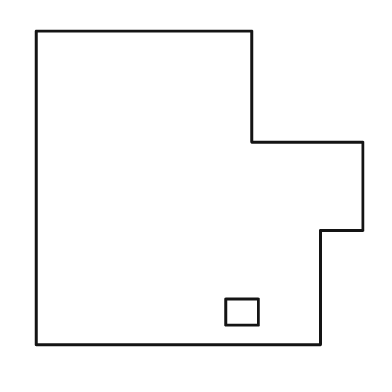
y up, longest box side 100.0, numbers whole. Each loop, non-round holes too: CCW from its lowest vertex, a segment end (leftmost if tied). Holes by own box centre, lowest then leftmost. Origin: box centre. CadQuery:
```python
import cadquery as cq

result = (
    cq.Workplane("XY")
    .moveTo(-50.0, -48.0)
    .lineTo(37.0, -48.0)
    .lineTo(37.0, -13.0)
    .lineTo(50.0, -13.0)
    .lineTo(50.0, 14.0)
    .lineTo(16.0, 14.0)
    .lineTo(16.0, 48.0)
    .lineTo(-50.0, 48.0)
    .close()
    .moveTo(8.0, -42.0)
    .lineTo(18.0, -42.0)
    .lineTo(18.0, -34.0)
    .lineTo(8.0, -34.0)
    .close()
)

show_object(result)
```